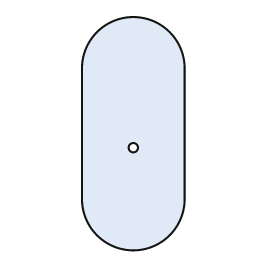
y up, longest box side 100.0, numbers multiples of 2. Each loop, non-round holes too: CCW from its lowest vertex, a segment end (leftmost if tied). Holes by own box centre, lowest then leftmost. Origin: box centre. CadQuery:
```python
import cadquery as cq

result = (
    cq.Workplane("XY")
    .moveTo(-22.0, -28.0)
    .threePointArc((0.0, -50.0), (22.0, -28.0))
    .lineTo(22.0, 28.0)
    .threePointArc((0.0, 50.0), (-22.0, 28.0))
    .close()
    .moveTo(0.0, -6.0)
    .circle(2.0)
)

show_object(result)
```